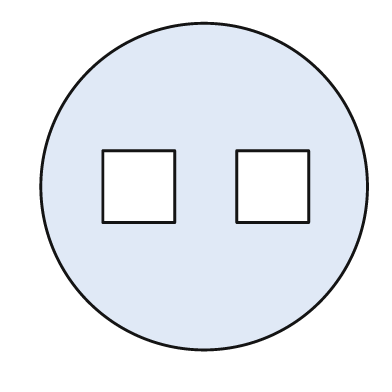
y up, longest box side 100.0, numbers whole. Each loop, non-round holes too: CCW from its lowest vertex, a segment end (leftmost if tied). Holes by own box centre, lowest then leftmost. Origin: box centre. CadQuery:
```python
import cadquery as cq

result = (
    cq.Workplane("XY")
    .moveTo(0.0, 0.0)
    .circle(50.0)
    .moveTo(-31.0, -11.0)
    .lineTo(-9.0, -11.0)
    .lineTo(-9.0, 11.0)
    .lineTo(-31.0, 11.0)
    .close()
    .moveTo(10.0, -11.0)
    .lineTo(32.0, -11.0)
    .lineTo(32.0, 11.0)
    .lineTo(10.0, 11.0)
    .close()
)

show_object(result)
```